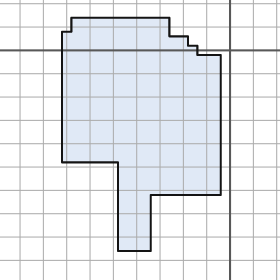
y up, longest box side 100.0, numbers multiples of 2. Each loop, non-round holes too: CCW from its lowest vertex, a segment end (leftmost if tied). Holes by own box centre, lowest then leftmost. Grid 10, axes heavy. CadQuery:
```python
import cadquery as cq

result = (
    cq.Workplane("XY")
    .moveTo(-48.0, -86.0)
    .lineTo(-34.0, -86.0)
    .lineTo(-34.0, -62.0)
    .lineTo(-4.0, -62.0)
    .lineTo(-4.0, -2.0)
    .lineTo(-14.0, -2.0)
    .lineTo(-14.0, 2.0)
    .lineTo(-18.0, 2.0)
    .lineTo(-18.0, 6.0)
    .lineTo(-26.0, 6.0)
    .lineTo(-26.0, 14.0)
    .lineTo(-68.0, 14.0)
    .lineTo(-68.0, 8.0)
    .lineTo(-72.0, 8.0)
    .lineTo(-72.0, -48.0)
    .lineTo(-48.0, -48.0)
    .close()
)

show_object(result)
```